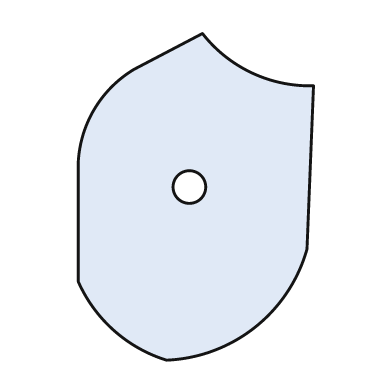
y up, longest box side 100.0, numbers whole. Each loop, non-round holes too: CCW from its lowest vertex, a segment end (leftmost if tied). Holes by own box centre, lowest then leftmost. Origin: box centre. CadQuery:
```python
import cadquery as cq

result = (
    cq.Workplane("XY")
    .moveTo(-9.0, -50.0)
    .threePointArc((18.0, -40.0), (34.0, -16.0))
    .lineTo(36.0, 34.0)
    .threePointArc((17.0, 38.0), (2.0, 50.0))
    .lineTo(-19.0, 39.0)
    .threePointArc((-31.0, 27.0), (-36.0, 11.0))
    .lineTo(-36.0, -26.0)
    .threePointArc((-25.0, -41.0), (-9.0, -50.0))
    .close()
    .moveTo(-2.0, 3.0)
    .circle(5.0)
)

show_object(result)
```